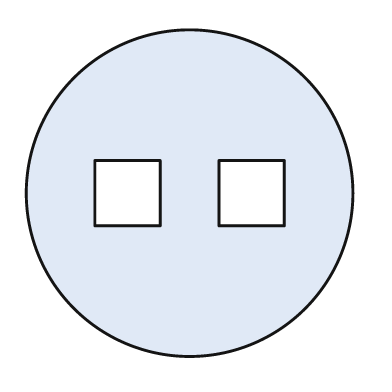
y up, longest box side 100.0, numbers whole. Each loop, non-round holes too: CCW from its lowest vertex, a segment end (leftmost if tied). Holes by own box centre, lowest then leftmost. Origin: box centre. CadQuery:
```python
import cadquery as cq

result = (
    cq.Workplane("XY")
    .moveTo(0.0, 0.0)
    .circle(50.0)
    .moveTo(-29.0, -10.0)
    .lineTo(-9.0, -10.0)
    .lineTo(-9.0, 10.0)
    .lineTo(-29.0, 10.0)
    .close()
    .moveTo(9.0, -10.0)
    .lineTo(29.0, -10.0)
    .lineTo(29.0, 10.0)
    .lineTo(9.0, 10.0)
    .close()
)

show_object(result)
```